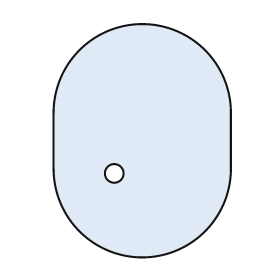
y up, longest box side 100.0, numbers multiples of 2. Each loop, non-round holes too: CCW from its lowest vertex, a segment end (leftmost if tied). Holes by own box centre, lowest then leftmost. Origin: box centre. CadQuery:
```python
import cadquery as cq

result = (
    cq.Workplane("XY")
    .moveTo(-38.0, -12.0)
    .threePointArc((0.0, -50.0), (38.0, -12.0))
    .lineTo(38.0, 12.0)
    .threePointArc((0.0, 50.0), (-38.0, 12.0))
    .close()
    .moveTo(-12.0, -14.0)
    .circle(4.0)
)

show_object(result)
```